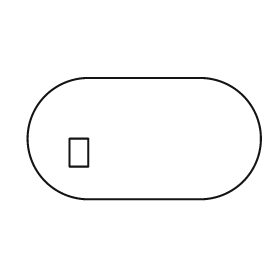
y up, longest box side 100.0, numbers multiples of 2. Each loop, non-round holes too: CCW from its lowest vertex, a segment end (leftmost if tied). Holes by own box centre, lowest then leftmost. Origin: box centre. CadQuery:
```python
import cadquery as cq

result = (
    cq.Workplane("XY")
    .moveTo(-24.0, -26.0)
    .lineTo(24.0, -26.0)
    .threePointArc((50.0, 0.0), (24.0, 26.0))
    .lineTo(-24.0, 26.0)
    .threePointArc((-50.0, 0.0), (-24.0, -26.0))
    .close()
    .moveTo(-32.0, -12.0)
    .lineTo(-24.0, -12.0)
    .lineTo(-24.0, 0.0)
    .lineTo(-32.0, 0.0)
    .close()
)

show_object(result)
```